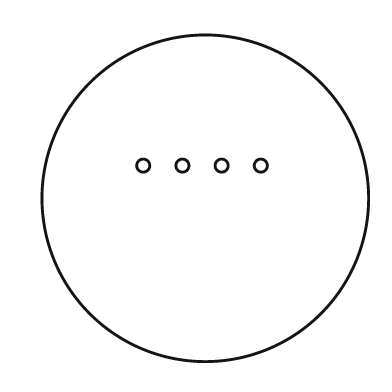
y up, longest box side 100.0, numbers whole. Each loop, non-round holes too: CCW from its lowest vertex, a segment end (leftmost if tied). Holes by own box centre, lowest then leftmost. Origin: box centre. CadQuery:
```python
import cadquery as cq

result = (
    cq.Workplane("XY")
    .moveTo(0.0, 0.0)
    .circle(50.0)
    .moveTo(-19.0, 10.0)
    .circle(2.0)
    .moveTo(-7.0, 10.0)
    .circle(2.0)
    .moveTo(5.0, 10.0)
    .circle(2.0)
    .moveTo(17.0, 10.0)
    .circle(2.0)
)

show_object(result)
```